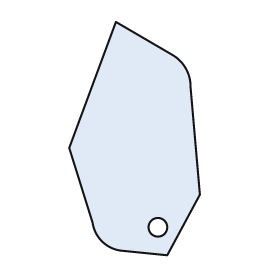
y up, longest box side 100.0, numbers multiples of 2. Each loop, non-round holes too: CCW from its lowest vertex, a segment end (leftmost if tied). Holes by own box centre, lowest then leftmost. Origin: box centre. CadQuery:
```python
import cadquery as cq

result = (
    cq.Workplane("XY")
    .moveTo(14.0, -50.0)
    .lineTo(28.0, -24.0)
    .lineTo(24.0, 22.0)
    .threePointArc((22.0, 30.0), (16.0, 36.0))
    .lineTo(-8.0, 50.0)
    .lineTo(-28.0, -4.0)
    .lineTo(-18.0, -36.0)
    .threePointArc((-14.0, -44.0), (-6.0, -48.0))
    .close()
    .moveTo(10.0, -38.0)
    .circle(4.0)
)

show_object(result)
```